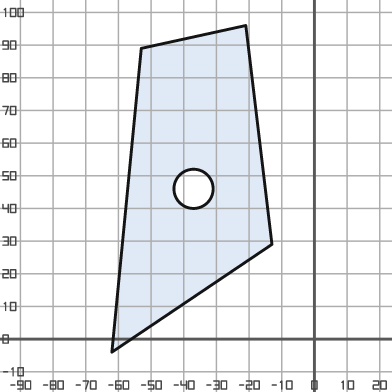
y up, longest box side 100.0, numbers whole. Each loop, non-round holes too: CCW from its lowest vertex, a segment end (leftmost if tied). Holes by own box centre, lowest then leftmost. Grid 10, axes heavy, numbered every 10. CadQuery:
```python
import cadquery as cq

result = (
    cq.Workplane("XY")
    .moveTo(-62.0, -4.0)
    .lineTo(-13.0, 29.0)
    .lineTo(-21.0, 96.0)
    .lineTo(-53.0, 89.0)
    .close()
    .moveTo(-37.0, 46.0)
    .circle(6.0)
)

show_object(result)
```